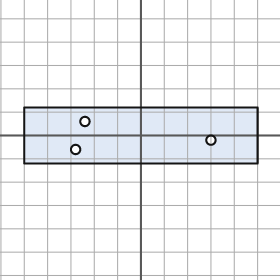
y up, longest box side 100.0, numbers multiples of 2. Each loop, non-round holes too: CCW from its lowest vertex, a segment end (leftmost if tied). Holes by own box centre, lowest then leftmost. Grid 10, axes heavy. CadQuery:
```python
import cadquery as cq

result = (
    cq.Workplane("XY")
    .moveTo(-50.0, -12.0)
    .lineTo(50.0, -12.0)
    .lineTo(50.0, 12.0)
    .lineTo(-50.0, 12.0)
    .close()
    .moveTo(-28.0, -6.0)
    .circle(2.0)
    .moveTo(30.0, -2.0)
    .circle(2.0)
    .moveTo(-24.0, 6.0)
    .circle(2.0)
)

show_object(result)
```